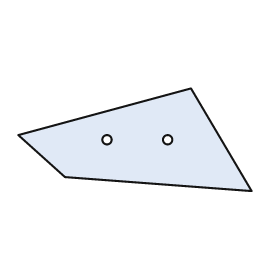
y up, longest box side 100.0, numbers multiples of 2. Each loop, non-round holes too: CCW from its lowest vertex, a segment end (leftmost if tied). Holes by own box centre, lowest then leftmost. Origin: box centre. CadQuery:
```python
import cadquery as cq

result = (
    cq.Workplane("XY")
    .moveTo(50.0, -22.0)
    .lineTo(24.0, 22.0)
    .lineTo(-50.0, 2.0)
    .lineTo(-30.0, -16.0)
    .close()
    .moveTo(-12.0, 0.0)
    .circle(2.0)
    .moveTo(14.0, 0.0)
    .circle(2.0)
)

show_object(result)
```